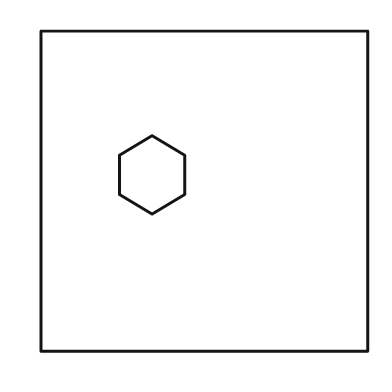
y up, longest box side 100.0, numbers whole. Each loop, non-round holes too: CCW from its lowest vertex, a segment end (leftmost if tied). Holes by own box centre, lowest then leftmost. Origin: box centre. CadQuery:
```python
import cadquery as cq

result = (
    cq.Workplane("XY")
    .moveTo(-50.0, -49.0)
    .lineTo(50.0, -49.0)
    .lineTo(50.0, 49.0)
    .lineTo(-50.0, 49.0)
    .close()
    .moveTo(-16.0, -7.0)
    .lineTo(-6.0, -1.0)
    .lineTo(-6.0, 11.0)
    .lineTo(-16.0, 17.0)
    .lineTo(-26.0, 11.0)
    .lineTo(-26.0, -1.0)
    .close()
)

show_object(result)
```